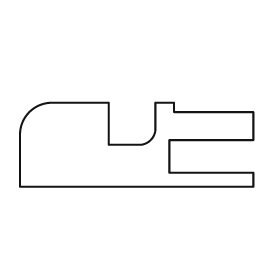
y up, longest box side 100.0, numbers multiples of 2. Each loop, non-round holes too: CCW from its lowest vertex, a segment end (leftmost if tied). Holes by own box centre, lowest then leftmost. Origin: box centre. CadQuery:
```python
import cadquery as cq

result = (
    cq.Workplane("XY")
    .moveTo(-50.0, -18.0)
    .lineTo(50.0, -18.0)
    .lineTo(50.0, -12.0)
    .lineTo(14.0, -12.0)
    .lineTo(14.0, 2.0)
    .lineTo(50.0, 2.0)
    .lineTo(50.0, 14.0)
    .lineTo(16.0, 14.0)
    .lineTo(16.0, 18.0)
    .lineTo(8.0, 18.0)
    .lineTo(8.0, 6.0)
    .threePointArc((6.0, 2.0), (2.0, 0.0))
    .lineTo(-12.0, 0.0)
    .lineTo(-12.0, 18.0)
    .lineTo(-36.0, 18.0)
    .threePointArc((-46.0, 14.0), (-50.0, 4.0))
    .close()
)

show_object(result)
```